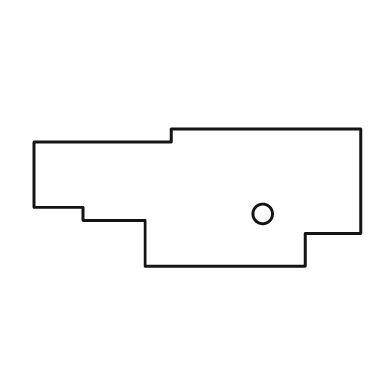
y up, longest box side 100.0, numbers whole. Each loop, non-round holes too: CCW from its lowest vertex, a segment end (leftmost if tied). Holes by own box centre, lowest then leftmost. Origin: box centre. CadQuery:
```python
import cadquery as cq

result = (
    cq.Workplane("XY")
    .moveTo(-16.0, -21.0)
    .lineTo(33.0, -21.0)
    .lineTo(33.0, -11.0)
    .lineTo(50.0, -11.0)
    .lineTo(50.0, 21.0)
    .lineTo(-8.0, 21.0)
    .lineTo(-8.0, 17.0)
    .lineTo(-50.0, 17.0)
    .lineTo(-50.0, -3.0)
    .lineTo(-35.0, -3.0)
    .lineTo(-35.0, -7.0)
    .lineTo(-16.0, -7.0)
    .close()
    .moveTo(20.0, -5.0)
    .circle(3.0)
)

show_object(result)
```